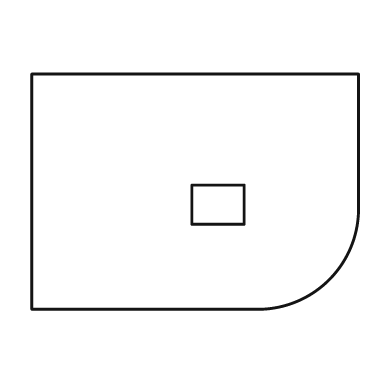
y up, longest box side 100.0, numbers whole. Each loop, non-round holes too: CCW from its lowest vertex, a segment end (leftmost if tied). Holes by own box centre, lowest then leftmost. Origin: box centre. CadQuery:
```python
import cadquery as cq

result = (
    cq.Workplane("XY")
    .moveTo(-50.0, -36.0)
    .lineTo(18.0, -36.0)
    .threePointArc((41.0, -27.0), (50.0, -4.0))
    .lineTo(50.0, 36.0)
    .lineTo(-50.0, 36.0)
    .close()
    .moveTo(-1.0, -10.0)
    .lineTo(15.0, -10.0)
    .lineTo(15.0, 2.0)
    .lineTo(-1.0, 2.0)
    .close()
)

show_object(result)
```